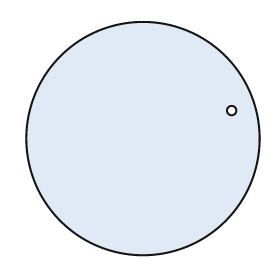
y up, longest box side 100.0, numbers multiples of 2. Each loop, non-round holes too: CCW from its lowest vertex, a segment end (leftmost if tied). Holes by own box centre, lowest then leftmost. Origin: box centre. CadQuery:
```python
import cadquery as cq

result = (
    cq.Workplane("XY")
    .moveTo(0.0, 0.0)
    .circle(50.0)
    .moveTo(38.0, 12.0)
    .circle(2.0)
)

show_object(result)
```